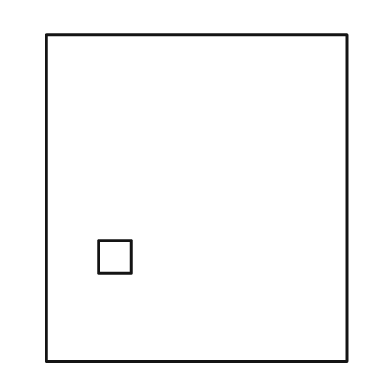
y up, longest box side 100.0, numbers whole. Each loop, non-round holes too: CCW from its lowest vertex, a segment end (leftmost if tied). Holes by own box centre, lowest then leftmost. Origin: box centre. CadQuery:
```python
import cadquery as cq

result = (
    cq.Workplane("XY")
    .moveTo(-46.0, -50.0)
    .lineTo(46.0, -50.0)
    .lineTo(46.0, 50.0)
    .lineTo(-46.0, 50.0)
    .close()
    .moveTo(-30.0, -23.0)
    .lineTo(-20.0, -23.0)
    .lineTo(-20.0, -13.0)
    .lineTo(-30.0, -13.0)
    .close()
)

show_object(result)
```